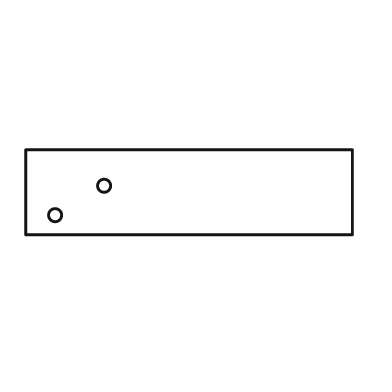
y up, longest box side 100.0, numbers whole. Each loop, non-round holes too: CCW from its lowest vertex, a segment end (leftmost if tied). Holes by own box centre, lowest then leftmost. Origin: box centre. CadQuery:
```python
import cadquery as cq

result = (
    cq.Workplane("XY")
    .moveTo(-50.0, -13.0)
    .lineTo(50.0, -13.0)
    .lineTo(50.0, 13.0)
    .lineTo(-50.0, 13.0)
    .close()
    .moveTo(-41.0, -7.0)
    .circle(2.0)
    .moveTo(-26.0, 2.0)
    .circle(2.0)
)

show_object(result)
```